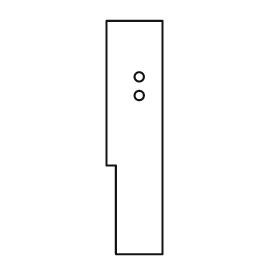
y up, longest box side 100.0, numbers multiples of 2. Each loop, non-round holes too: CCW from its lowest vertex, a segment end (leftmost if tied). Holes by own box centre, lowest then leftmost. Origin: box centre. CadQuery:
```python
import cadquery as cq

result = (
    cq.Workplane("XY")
    .moveTo(-8.0, -50.0)
    .lineTo(12.0, -50.0)
    .lineTo(12.0, 50.0)
    .lineTo(-12.0, 50.0)
    .lineTo(-12.0, -12.0)
    .lineTo(-8.0, -12.0)
    .close()
    .moveTo(2.0, 18.0)
    .circle(2.0)
    .moveTo(2.0, 26.0)
    .circle(2.0)
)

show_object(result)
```